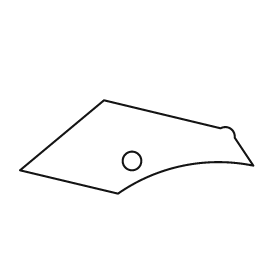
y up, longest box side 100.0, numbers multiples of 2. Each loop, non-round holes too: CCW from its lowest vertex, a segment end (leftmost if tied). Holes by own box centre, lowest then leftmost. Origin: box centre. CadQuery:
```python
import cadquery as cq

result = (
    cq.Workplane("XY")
    .moveTo(-8.0, -20.0)
    .threePointArc((20.0, -8.0), (50.0, -8.0))
    .lineTo(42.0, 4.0)
    .threePointArc((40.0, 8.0), (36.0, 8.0))
    .lineTo(-14.0, 20.0)
    .lineTo(-50.0, -10.0)
    .close()
    .moveTo(-2.0, -6.0)
    .circle(4.0)
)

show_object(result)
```